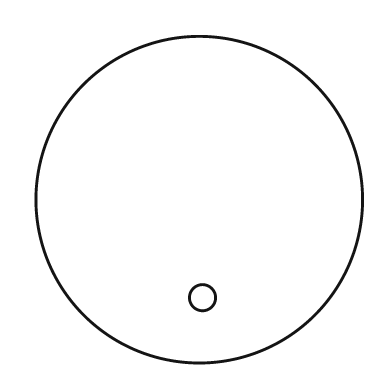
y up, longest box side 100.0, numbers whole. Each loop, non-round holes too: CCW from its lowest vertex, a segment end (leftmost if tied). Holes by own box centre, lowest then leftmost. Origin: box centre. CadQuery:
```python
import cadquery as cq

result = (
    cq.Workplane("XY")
    .moveTo(0.0, 0.0)
    .circle(50.0)
    .moveTo(1.0, -30.0)
    .circle(4.0)
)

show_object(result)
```